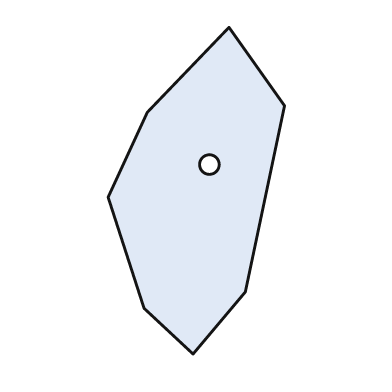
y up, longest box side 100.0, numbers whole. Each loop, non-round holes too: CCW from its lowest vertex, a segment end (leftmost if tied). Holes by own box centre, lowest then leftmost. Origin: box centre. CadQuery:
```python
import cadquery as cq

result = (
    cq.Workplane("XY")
    .moveTo(-1.0, -50.0)
    .lineTo(15.0, -31.0)
    .lineTo(27.0, 26.0)
    .lineTo(10.0, 50.0)
    .lineTo(-15.0, 24.0)
    .lineTo(-27.0, -2.0)
    .lineTo(-16.0, -36.0)
    .close()
    .moveTo(4.0, 8.0)
    .circle(3.0)
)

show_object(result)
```